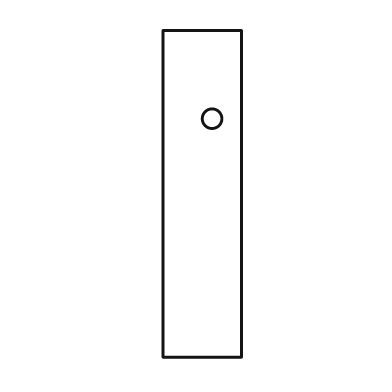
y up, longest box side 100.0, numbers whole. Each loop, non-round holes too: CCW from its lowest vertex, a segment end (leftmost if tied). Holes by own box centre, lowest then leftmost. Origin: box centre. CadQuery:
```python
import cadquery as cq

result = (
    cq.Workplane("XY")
    .moveTo(-12.0, -50.0)
    .lineTo(12.0, -50.0)
    .lineTo(12.0, 50.0)
    .lineTo(-12.0, 50.0)
    .close()
    .moveTo(3.0, 23.0)
    .circle(3.0)
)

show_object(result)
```